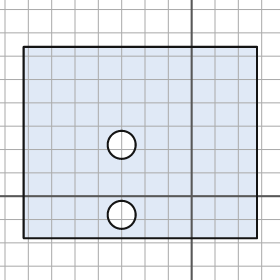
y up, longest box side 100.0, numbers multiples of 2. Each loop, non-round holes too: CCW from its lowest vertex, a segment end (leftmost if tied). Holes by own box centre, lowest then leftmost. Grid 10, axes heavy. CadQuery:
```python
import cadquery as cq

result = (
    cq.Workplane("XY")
    .moveTo(-72.0, -18.0)
    .lineTo(28.0, -18.0)
    .lineTo(28.0, 64.0)
    .lineTo(-72.0, 64.0)
    .close()
    .moveTo(-30.0, -8.0)
    .circle(6.0)
    .moveTo(-30.0, 22.0)
    .circle(6.0)
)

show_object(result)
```